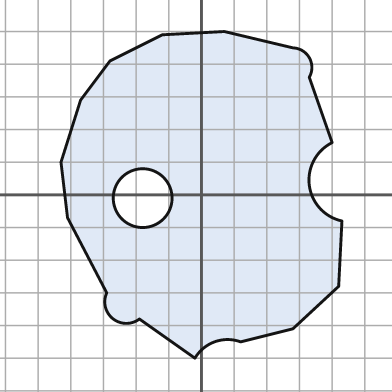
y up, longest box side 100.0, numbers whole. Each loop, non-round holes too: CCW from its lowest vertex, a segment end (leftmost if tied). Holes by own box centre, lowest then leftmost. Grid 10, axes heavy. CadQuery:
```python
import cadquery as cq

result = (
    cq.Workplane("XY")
    .moveTo(-2.0, -50.0)
    .threePointArc((4.0, -45.0), (12.0, -45.0))
    .lineTo(28.0, -41.0)
    .lineTo(42.0, -28.0)
    .lineTo(43.0, -8.0)
    .threePointArc((33.0, 3.0), (40.0, 16.0))
    .lineTo(33.0, 36.0)
    .threePointArc((33.0, 42.0), (28.0, 45.0))
    .lineTo(7.0, 50.0)
    .lineTo(-12.0, 49.0)
    .lineTo(-28.0, 41.0)
    .lineTo(-37.0, 29.0)
    .lineTo(-43.0, 10.0)
    .lineTo(-41.0, -7.0)
    .lineTo(-29.0, -30.0)
    .threePointArc((-27.0, -38.0), (-19.0, -38.0))
    .close()
    .moveTo(-18.0, -1.0)
    .circle(9.0)
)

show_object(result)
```